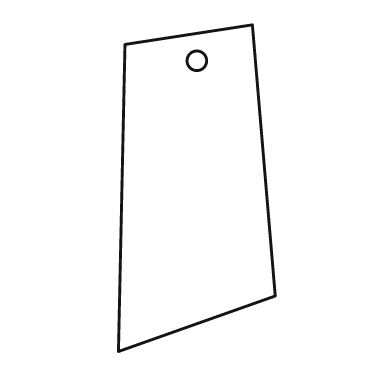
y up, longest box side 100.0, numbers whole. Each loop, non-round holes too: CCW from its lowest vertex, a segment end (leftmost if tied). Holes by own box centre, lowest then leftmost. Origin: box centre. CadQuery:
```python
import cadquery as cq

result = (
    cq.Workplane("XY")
    .moveTo(-24.0, -50.0)
    .lineTo(24.0, -33.0)
    .lineTo(17.0, 50.0)
    .lineTo(-22.0, 44.0)
    .close()
    .moveTo(0.0, 39.0)
    .circle(3.0)
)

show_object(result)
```